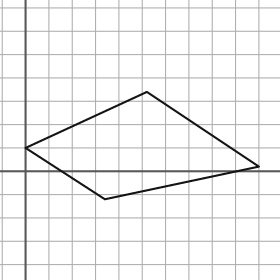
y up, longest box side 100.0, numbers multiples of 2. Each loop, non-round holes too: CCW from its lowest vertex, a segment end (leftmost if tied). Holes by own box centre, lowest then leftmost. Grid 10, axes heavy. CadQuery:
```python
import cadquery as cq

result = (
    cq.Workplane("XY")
    .moveTo(34.0, -12.0)
    .lineTo(100.0, 2.0)
    .lineTo(52.0, 34.0)
    .lineTo(0.0, 10.0)
    .close()
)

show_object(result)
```